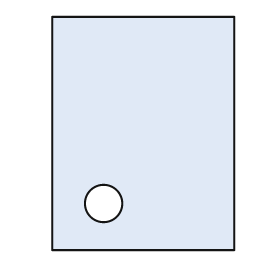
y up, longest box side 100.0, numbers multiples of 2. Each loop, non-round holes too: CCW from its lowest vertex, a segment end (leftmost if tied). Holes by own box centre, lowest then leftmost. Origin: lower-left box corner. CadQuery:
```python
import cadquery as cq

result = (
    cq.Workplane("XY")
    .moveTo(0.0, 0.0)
    .lineTo(78.0, 0.0)
    .lineTo(78.0, 100.0)
    .lineTo(0.0, 100.0)
    .close()
    .moveTo(22.0, 20.0)
    .circle(8.0)
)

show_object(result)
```